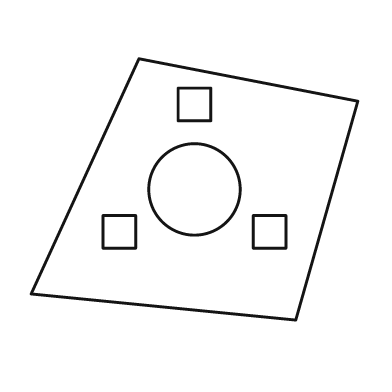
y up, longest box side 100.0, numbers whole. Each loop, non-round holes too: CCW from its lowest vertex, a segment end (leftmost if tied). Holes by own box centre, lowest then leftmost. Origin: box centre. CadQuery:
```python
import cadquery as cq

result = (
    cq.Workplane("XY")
    .moveTo(31.0, -40.0)
    .lineTo(50.0, 27.0)
    .lineTo(-17.0, 40.0)
    .lineTo(-50.0, -32.0)
    .close()
    .moveTo(-28.0, -18.0)
    .lineTo(-18.0, -18.0)
    .lineTo(-18.0, -8.0)
    .lineTo(-28.0, -8.0)
    .close()
    .moveTo(18.0, -18.0)
    .lineTo(28.0, -18.0)
    .lineTo(28.0, -8.0)
    .lineTo(18.0, -8.0)
    .close()
    .moveTo(0.0, 0.0)
    .circle(14.0)
    .moveTo(-5.0, 21.0)
    .lineTo(5.0, 21.0)
    .lineTo(5.0, 31.0)
    .lineTo(-5.0, 31.0)
    .close()
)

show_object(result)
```